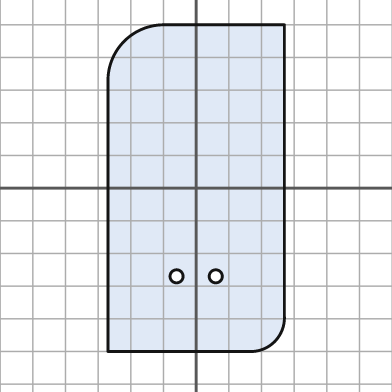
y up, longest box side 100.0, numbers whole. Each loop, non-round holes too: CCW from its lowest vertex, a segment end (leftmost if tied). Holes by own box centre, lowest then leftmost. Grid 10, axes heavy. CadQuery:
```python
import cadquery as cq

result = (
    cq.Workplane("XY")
    .moveTo(-27.0, -50.0)
    .lineTo(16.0, -50.0)
    .threePointArc((24.0, -47.0), (27.0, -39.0))
    .lineTo(27.0, 50.0)
    .lineTo(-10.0, 50.0)
    .threePointArc((-22.0, 45.0), (-27.0, 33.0))
    .close()
    .moveTo(-6.0, -27.0)
    .circle(2.0)
    .moveTo(6.0, -27.0)
    .circle(2.0)
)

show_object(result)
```